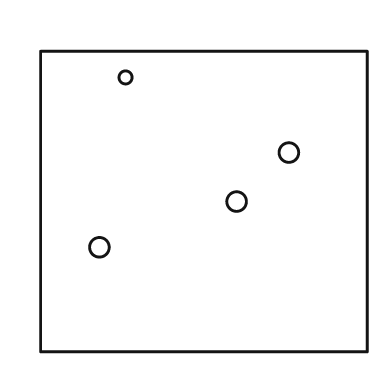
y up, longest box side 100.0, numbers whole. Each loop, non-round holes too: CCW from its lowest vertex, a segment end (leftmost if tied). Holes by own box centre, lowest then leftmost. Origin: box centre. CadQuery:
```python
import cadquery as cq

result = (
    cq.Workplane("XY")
    .moveTo(-50.0, -46.0)
    .lineTo(50.0, -46.0)
    .lineTo(50.0, 46.0)
    .lineTo(-50.0, 46.0)
    .close()
    .moveTo(-32.0, -14.0)
    .circle(3.0)
    .moveTo(10.0, 0.0)
    .circle(3.0)
    .moveTo(26.0, 15.0)
    .circle(3.0)
    .moveTo(-24.0, 38.0)
    .circle(2.0)
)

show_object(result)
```